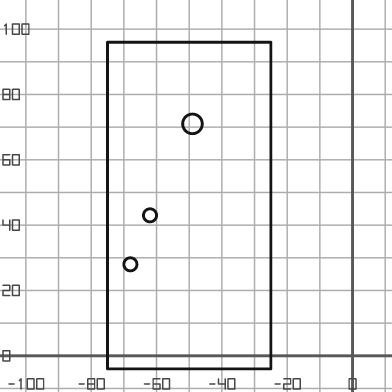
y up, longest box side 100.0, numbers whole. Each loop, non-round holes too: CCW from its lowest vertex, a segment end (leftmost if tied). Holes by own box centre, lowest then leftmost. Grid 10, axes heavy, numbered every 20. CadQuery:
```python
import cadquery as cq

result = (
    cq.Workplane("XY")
    .moveTo(-75.0, -4.0)
    .lineTo(-25.0, -4.0)
    .lineTo(-25.0, 96.0)
    .lineTo(-75.0, 96.0)
    .close()
    .moveTo(-68.0, 28.0)
    .circle(2.0)
    .moveTo(-62.0, 43.0)
    .circle(2.0)
    .moveTo(-49.0, 71.0)
    .circle(3.0)
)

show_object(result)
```